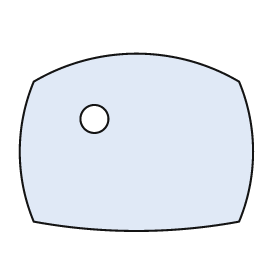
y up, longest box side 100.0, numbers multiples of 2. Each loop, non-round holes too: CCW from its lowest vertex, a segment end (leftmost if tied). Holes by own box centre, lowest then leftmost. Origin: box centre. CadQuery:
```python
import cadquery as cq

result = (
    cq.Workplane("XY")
    .moveTo(-44.0, -34.0)
    .threePointArc((0.0, -38.0), (44.0, -34.0))
    .threePointArc((50.0, -4.0), (44.0, 26.0))
    .threePointArc((0.0, 38.0), (-44.0, 26.0))
    .threePointArc((-50.0, -4.0), (-44.0, -34.0))
    .close()
    .moveTo(-18.0, 10.0)
    .circle(6.0)
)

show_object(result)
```